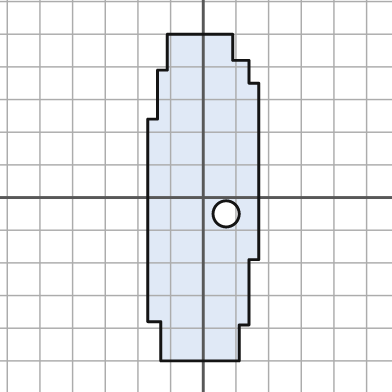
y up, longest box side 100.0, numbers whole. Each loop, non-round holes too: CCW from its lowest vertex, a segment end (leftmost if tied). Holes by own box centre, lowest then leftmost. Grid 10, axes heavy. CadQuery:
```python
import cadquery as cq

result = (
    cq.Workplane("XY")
    .moveTo(-13.0, -50.0)
    .lineTo(11.0, -50.0)
    .lineTo(11.0, -39.0)
    .lineTo(14.0, -39.0)
    .lineTo(14.0, -19.0)
    .lineTo(17.0, -19.0)
    .lineTo(17.0, 35.0)
    .lineTo(14.0, 35.0)
    .lineTo(14.0, 42.0)
    .lineTo(9.0, 42.0)
    .lineTo(9.0, 50.0)
    .lineTo(-11.0, 50.0)
    .lineTo(-11.0, 39.0)
    .lineTo(-14.0, 39.0)
    .lineTo(-14.0, 24.0)
    .lineTo(-17.0, 24.0)
    .lineTo(-17.0, -38.0)
    .lineTo(-13.0, -38.0)
    .close()
    .moveTo(7.0, -5.0)
    .circle(4.0)
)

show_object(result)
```